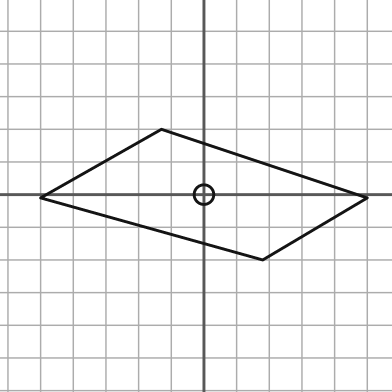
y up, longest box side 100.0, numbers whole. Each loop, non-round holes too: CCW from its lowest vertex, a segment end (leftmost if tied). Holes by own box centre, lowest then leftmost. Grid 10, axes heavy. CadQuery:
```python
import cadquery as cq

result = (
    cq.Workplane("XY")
    .moveTo(18.0, -20.0)
    .lineTo(50.0, -1.0)
    .lineTo(-13.0, 20.0)
    .lineTo(-50.0, -1.0)
    .close()
    .moveTo(0.0, 0.0)
    .circle(3.0)
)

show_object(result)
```